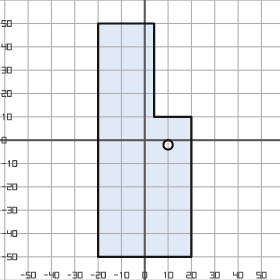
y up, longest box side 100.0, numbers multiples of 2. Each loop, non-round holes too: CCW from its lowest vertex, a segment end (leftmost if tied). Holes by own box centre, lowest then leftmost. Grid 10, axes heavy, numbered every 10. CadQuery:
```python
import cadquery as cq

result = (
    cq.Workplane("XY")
    .moveTo(-20.0, -50.0)
    .lineTo(20.0, -50.0)
    .lineTo(20.0, 10.0)
    .lineTo(4.0, 10.0)
    .lineTo(4.0, 50.0)
    .lineTo(-20.0, 50.0)
    .close()
    .moveTo(10.0, -2.0)
    .circle(2.0)
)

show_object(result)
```